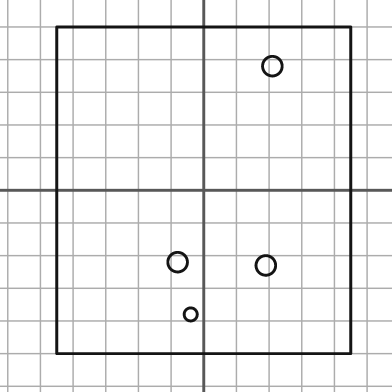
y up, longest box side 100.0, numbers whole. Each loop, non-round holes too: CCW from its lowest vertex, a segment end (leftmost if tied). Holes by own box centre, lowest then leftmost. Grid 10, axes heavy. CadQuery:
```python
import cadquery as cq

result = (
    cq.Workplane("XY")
    .moveTo(-45.0, -50.0)
    .lineTo(45.0, -50.0)
    .lineTo(45.0, 50.0)
    .lineTo(-45.0, 50.0)
    .close()
    .moveTo(-4.0, -38.0)
    .circle(2.0)
    .moveTo(19.0, -23.0)
    .circle(3.0)
    .moveTo(-8.0, -22.0)
    .circle(3.0)
    .moveTo(21.0, 38.0)
    .circle(3.0)
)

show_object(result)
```